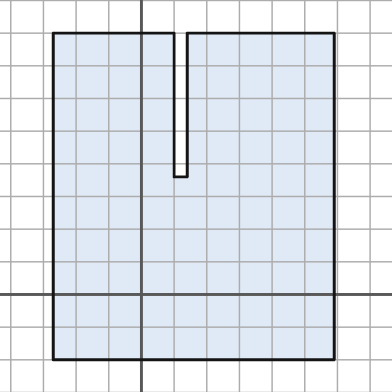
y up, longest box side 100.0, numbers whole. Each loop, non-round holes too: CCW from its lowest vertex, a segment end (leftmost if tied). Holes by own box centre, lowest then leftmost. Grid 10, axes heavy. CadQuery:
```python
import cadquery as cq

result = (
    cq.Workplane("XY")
    .moveTo(-27.0, -20.0)
    .lineTo(59.0, -20.0)
    .lineTo(59.0, 80.0)
    .lineTo(14.0, 80.0)
    .lineTo(14.0, 36.0)
    .lineTo(10.0, 36.0)
    .lineTo(10.0, 80.0)
    .lineTo(-27.0, 80.0)
    .close()
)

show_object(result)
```